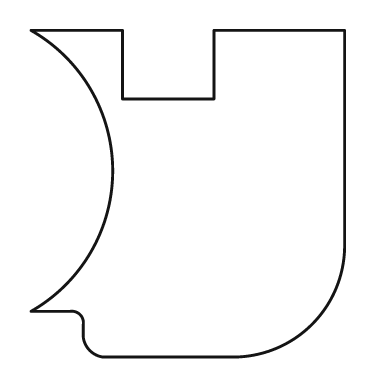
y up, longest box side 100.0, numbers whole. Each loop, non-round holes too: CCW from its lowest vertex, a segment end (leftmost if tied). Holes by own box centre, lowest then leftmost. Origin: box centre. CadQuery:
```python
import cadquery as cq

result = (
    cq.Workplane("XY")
    .moveTo(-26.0, -50.0)
    .lineTo(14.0, -50.0)
    .threePointArc((38.0, -40.0), (48.0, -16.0))
    .lineTo(48.0, 50.0)
    .lineTo(8.0, 50.0)
    .lineTo(8.0, 29.0)
    .lineTo(-20.0, 29.0)
    .lineTo(-20.0, 50.0)
    .lineTo(-48.0, 50.0)
    .threePointArc((-23.0, 7.0), (-48.0, -36.0))
    .lineTo(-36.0, -36.0)
    .threePointArc((-33.0, -37.0), (-32.0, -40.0))
    .lineTo(-32.0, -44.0)
    .threePointArc((-30.0, -48.0), (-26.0, -50.0))
    .close()
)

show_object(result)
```